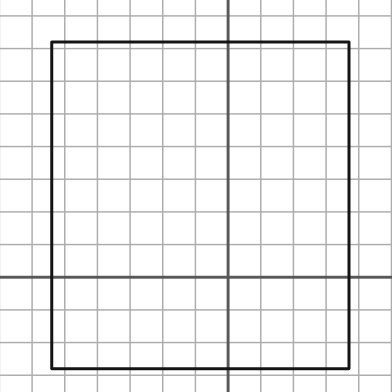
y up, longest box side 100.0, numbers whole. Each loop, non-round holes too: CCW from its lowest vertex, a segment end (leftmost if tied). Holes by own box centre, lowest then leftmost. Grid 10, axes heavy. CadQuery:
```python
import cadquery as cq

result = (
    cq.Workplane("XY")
    .moveTo(-54.0, -28.0)
    .lineTo(37.0, -28.0)
    .lineTo(37.0, 72.0)
    .lineTo(-54.0, 72.0)
    .close()
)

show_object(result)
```